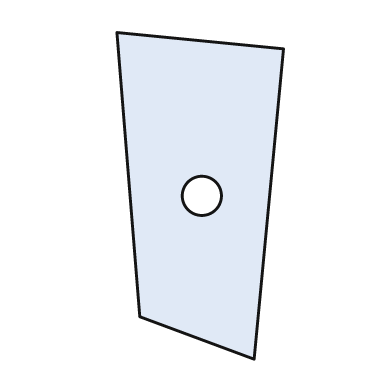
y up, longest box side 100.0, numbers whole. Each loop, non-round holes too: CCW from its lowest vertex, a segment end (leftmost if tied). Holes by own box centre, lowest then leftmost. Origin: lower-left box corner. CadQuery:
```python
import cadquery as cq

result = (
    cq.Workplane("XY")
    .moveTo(42.0, 0.0)
    .lineTo(51.0, 95.0)
    .lineTo(0.0, 100.0)
    .lineTo(7.0, 13.0)
    .close()
    .moveTo(26.0, 50.0)
    .circle(6.0)
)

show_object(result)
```